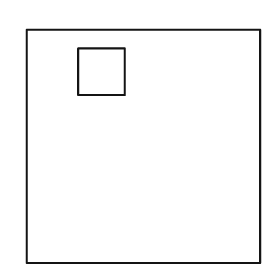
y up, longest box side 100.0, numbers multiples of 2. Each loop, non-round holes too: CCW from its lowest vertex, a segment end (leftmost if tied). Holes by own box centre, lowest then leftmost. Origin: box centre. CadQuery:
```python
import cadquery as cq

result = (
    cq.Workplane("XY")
    .moveTo(-50.0, -50.0)
    .lineTo(50.0, -50.0)
    .lineTo(50.0, 50.0)
    .lineTo(-50.0, 50.0)
    .close()
    .moveTo(-28.0, 22.0)
    .lineTo(-8.0, 22.0)
    .lineTo(-8.0, 42.0)
    .lineTo(-28.0, 42.0)
    .close()
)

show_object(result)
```